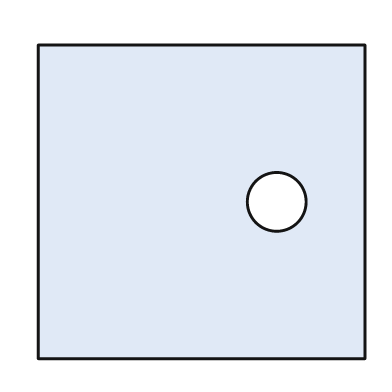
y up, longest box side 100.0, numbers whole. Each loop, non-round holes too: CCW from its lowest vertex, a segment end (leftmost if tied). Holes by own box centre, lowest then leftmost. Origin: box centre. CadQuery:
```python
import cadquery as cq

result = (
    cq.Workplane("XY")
    .moveTo(-50.0, -48.0)
    .lineTo(50.0, -48.0)
    .lineTo(50.0, 48.0)
    .lineTo(-50.0, 48.0)
    .close()
    .moveTo(23.0, 0.0)
    .circle(9.0)
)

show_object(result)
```